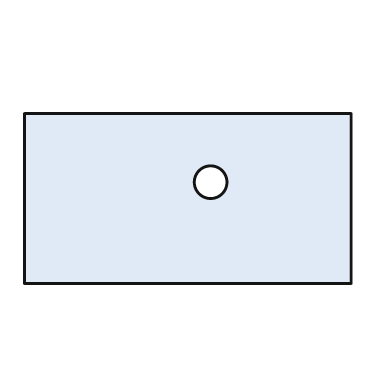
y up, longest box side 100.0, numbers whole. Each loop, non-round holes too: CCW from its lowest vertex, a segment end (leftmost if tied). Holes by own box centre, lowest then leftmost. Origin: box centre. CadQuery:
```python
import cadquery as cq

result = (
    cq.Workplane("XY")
    .moveTo(-50.0, -26.0)
    .lineTo(50.0, -26.0)
    .lineTo(50.0, 26.0)
    .lineTo(-50.0, 26.0)
    .close()
    .moveTo(7.0, 5.0)
    .circle(5.0)
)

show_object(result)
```